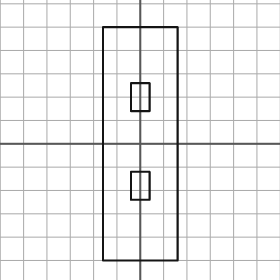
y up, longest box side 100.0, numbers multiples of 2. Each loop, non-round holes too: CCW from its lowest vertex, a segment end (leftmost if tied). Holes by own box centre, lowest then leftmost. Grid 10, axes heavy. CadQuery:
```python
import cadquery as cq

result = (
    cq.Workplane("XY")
    .moveTo(-16.0, -50.0)
    .lineTo(16.0, -50.0)
    .lineTo(16.0, 50.0)
    .lineTo(-16.0, 50.0)
    .close()
    .moveTo(-4.0, -24.0)
    .lineTo(4.0, -24.0)
    .lineTo(4.0, -12.0)
    .lineTo(-4.0, -12.0)
    .close()
    .moveTo(-4.0, 14.0)
    .lineTo(4.0, 14.0)
    .lineTo(4.0, 26.0)
    .lineTo(-4.0, 26.0)
    .close()
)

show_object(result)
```